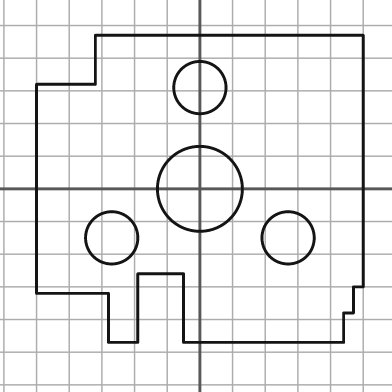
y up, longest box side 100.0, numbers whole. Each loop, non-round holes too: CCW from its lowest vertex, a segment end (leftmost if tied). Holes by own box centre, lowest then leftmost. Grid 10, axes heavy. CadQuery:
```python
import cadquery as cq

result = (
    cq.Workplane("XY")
    .moveTo(-28.0, -47.0)
    .lineTo(-19.0, -47.0)
    .lineTo(-19.0, -26.0)
    .lineTo(-5.0, -26.0)
    .lineTo(-5.0, -47.0)
    .lineTo(44.0, -47.0)
    .lineTo(44.0, -38.0)
    .lineTo(47.0, -38.0)
    .lineTo(47.0, -30.0)
    .lineTo(50.0, -30.0)
    .lineTo(50.0, 47.0)
    .lineTo(-32.0, 47.0)
    .lineTo(-32.0, 32.0)
    .lineTo(-50.0, 32.0)
    .lineTo(-50.0, -32.0)
    .lineTo(-28.0, -32.0)
    .close()
    .moveTo(-27.0, -15.0)
    .circle(8.0)
    .moveTo(27.0, -15.0)
    .circle(8.0)
    .moveTo(0.0, 0.0)
    .circle(13.0)
    .moveTo(0.0, 31.0)
    .circle(8.0)
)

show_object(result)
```